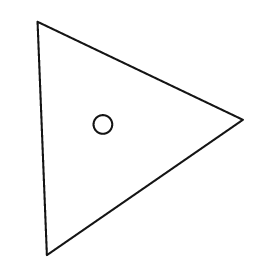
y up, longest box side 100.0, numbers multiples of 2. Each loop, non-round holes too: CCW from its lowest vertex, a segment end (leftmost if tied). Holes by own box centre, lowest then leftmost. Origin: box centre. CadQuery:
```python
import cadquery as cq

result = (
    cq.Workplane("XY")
    .moveTo(-40.0, -50.0)
    .lineTo(44.0, 8.0)
    .lineTo(-44.0, 50.0)
    .close()
    .moveTo(-16.0, 6.0)
    .circle(4.0)
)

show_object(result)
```